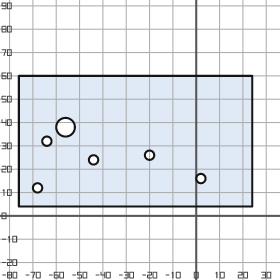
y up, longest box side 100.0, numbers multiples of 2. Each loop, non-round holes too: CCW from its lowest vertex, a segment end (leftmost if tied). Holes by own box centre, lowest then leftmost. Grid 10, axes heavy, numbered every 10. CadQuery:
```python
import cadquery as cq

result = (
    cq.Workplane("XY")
    .moveTo(-76.0, 4.0)
    .lineTo(24.0, 4.0)
    .lineTo(24.0, 60.0)
    .lineTo(-76.0, 60.0)
    .close()
    .moveTo(-68.0, 12.0)
    .circle(2.0)
    .moveTo(2.0, 16.0)
    .circle(2.0)
    .moveTo(-44.0, 24.0)
    .circle(2.0)
    .moveTo(-20.0, 26.0)
    .circle(2.0)
    .moveTo(-64.0, 32.0)
    .circle(2.0)
    .moveTo(-56.0, 38.0)
    .circle(4.0)
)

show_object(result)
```